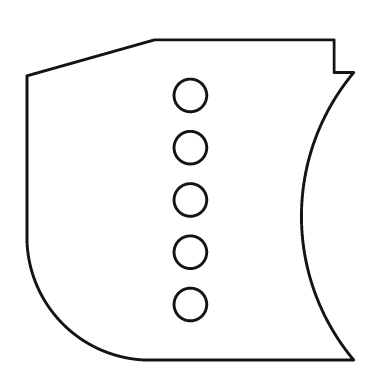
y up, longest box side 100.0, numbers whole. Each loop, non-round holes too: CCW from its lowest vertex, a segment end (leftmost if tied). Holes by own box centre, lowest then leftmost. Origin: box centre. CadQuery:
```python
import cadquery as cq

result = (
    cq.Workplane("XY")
    .moveTo(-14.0, -49.0)
    .lineTo(50.0, -49.0)
    .threePointArc((34.0, -5.0), (50.0, 39.0))
    .lineTo(44.0, 39.0)
    .lineTo(44.0, 49.0)
    .lineTo(-11.0, 49.0)
    .lineTo(-50.0, 38.0)
    .lineTo(-50.0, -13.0)
    .threePointArc((-39.0, -38.0), (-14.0, -49.0))
    .close()
    .moveTo(0.0, -32.0)
    .circle(5.0)
    .moveTo(0.0, -16.0)
    .circle(5.0)
    .moveTo(0.0, 0.0)
    .circle(5.0)
    .moveTo(0.0, 16.0)
    .circle(5.0)
    .moveTo(0.0, 32.0)
    .circle(5.0)
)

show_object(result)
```